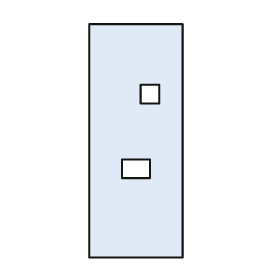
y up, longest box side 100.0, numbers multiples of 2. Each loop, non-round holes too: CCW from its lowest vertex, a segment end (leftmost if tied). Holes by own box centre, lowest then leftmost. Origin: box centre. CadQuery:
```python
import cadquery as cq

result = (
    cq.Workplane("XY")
    .moveTo(-20.0, -50.0)
    .lineTo(20.0, -50.0)
    .lineTo(20.0, 50.0)
    .lineTo(-20.0, 50.0)
    .close()
    .moveTo(-6.0, -16.0)
    .lineTo(6.0, -16.0)
    .lineTo(6.0, -8.0)
    .lineTo(-6.0, -8.0)
    .close()
    .moveTo(2.0, 16.0)
    .lineTo(10.0, 16.0)
    .lineTo(10.0, 24.0)
    .lineTo(2.0, 24.0)
    .close()
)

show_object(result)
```